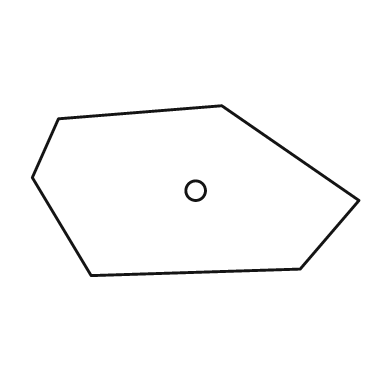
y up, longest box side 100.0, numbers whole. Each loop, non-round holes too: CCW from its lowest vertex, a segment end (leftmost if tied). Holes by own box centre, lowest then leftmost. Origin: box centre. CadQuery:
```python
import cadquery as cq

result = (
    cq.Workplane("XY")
    .moveTo(-32.0, -26.0)
    .lineTo(32.0, -24.0)
    .lineTo(50.0, -3.0)
    .lineTo(8.0, 26.0)
    .lineTo(-42.0, 22.0)
    .lineTo(-50.0, 4.0)
    .close()
    .moveTo(0.0, 0.0)
    .circle(3.0)
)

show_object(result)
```